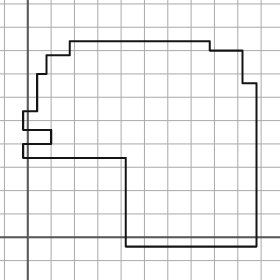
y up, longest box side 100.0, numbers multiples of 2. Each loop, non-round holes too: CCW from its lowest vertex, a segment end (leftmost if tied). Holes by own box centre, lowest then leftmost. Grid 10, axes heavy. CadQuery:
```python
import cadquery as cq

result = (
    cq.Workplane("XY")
    .moveTo(42.0, -4.0)
    .lineTo(98.0, -4.0)
    .lineTo(98.0, 66.0)
    .lineTo(92.0, 66.0)
    .lineTo(92.0, 80.0)
    .lineTo(78.0, 80.0)
    .lineTo(78.0, 84.0)
    .lineTo(18.0, 84.0)
    .lineTo(18.0, 78.0)
    .lineTo(8.0, 78.0)
    .lineTo(8.0, 70.0)
    .lineTo(4.0, 70.0)
    .lineTo(4.0, 54.0)
    .lineTo(-2.0, 54.0)
    .lineTo(-2.0, 46.0)
    .lineTo(10.0, 46.0)
    .lineTo(10.0, 40.0)
    .lineTo(-2.0, 40.0)
    .lineTo(-2.0, 34.0)
    .lineTo(42.0, 34.0)
    .close()
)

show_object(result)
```